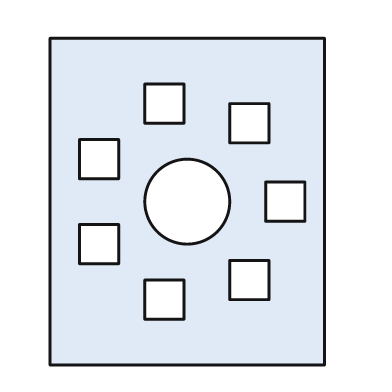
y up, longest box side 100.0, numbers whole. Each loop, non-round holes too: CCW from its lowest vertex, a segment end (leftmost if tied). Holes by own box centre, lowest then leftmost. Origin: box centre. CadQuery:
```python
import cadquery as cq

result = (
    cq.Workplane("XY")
    .moveTo(-42.0, -50.0)
    .lineTo(42.0, -50.0)
    .lineTo(42.0, 50.0)
    .lineTo(-42.0, 50.0)
    .close()
    .moveTo(-13.0, -36.0)
    .lineTo(-1.0, -36.0)
    .lineTo(-1.0, -24.0)
    .lineTo(-13.0, -24.0)
    .close()
    .moveTo(13.0, -30.0)
    .lineTo(25.0, -30.0)
    .lineTo(25.0, -18.0)
    .lineTo(13.0, -18.0)
    .close()
    .moveTo(-33.0, -19.0)
    .lineTo(-21.0, -19.0)
    .lineTo(-21.0, -7.0)
    .lineTo(-33.0, -7.0)
    .close()
    .moveTo(0.0, 0.0)
    .circle(13.0)
    .moveTo(24.0, -6.0)
    .lineTo(36.0, -6.0)
    .lineTo(36.0, 6.0)
    .lineTo(24.0, 6.0)
    .close()
    .moveTo(-33.0, 7.0)
    .lineTo(-21.0, 7.0)
    .lineTo(-21.0, 19.0)
    .lineTo(-33.0, 19.0)
    .close()
    .moveTo(13.0, 18.0)
    .lineTo(25.0, 18.0)
    .lineTo(25.0, 30.0)
    .lineTo(13.0, 30.0)
    .close()
    .moveTo(-13.0, 24.0)
    .lineTo(-1.0, 24.0)
    .lineTo(-1.0, 36.0)
    .lineTo(-13.0, 36.0)
    .close()
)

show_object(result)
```